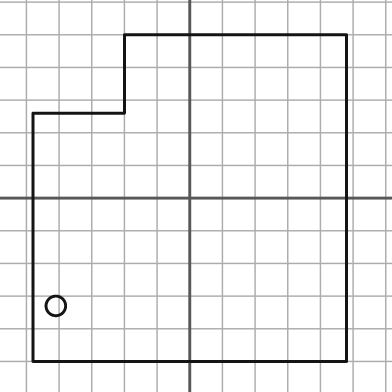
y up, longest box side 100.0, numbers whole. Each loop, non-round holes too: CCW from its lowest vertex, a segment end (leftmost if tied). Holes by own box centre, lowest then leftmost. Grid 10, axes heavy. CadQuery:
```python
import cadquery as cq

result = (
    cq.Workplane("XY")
    .moveTo(-48.0, -50.0)
    .lineTo(48.0, -50.0)
    .lineTo(48.0, 50.0)
    .lineTo(-20.0, 50.0)
    .lineTo(-20.0, 26.0)
    .lineTo(-48.0, 26.0)
    .close()
    .moveTo(-41.0, -33.0)
    .circle(3.0)
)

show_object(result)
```